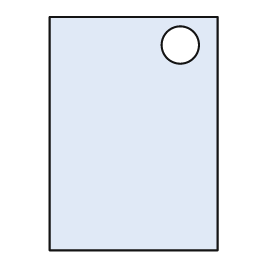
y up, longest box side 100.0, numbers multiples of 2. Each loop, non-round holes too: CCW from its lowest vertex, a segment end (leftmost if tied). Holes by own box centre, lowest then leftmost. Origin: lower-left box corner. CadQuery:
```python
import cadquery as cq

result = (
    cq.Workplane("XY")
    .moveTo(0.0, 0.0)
    .lineTo(72.0, 0.0)
    .lineTo(72.0, 100.0)
    .lineTo(0.0, 100.0)
    .close()
    .moveTo(56.0, 88.0)
    .circle(8.0)
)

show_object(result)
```